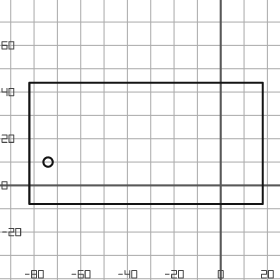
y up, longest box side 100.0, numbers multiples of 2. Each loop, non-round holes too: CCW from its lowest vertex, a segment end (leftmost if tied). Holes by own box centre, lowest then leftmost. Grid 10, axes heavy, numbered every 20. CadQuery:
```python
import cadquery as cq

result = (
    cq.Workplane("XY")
    .moveTo(-82.0, -8.0)
    .lineTo(18.0, -8.0)
    .lineTo(18.0, 44.0)
    .lineTo(-82.0, 44.0)
    .close()
    .moveTo(-74.0, 10.0)
    .circle(2.0)
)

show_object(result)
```